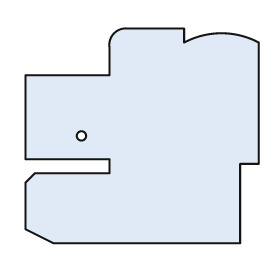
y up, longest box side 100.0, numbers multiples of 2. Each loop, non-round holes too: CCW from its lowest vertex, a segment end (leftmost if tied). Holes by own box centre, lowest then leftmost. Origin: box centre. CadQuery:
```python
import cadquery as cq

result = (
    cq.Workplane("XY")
    .moveTo(-38.0, -46.0)
    .lineTo(42.0, -46.0)
    .lineTo(42.0, -12.0)
    .lineTo(50.0, -12.0)
    .lineTo(50.0, 40.0)
    .threePointArc((34.0, 44.0), (18.0, 40.0))
    .lineTo(18.0, 46.0)
    .lineTo(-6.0, 46.0)
    .threePointArc((-12.0, 44.0), (-14.0, 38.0))
    .lineTo(-14.0, 26.0)
    .lineTo(-50.0, 26.0)
    .lineTo(-50.0, -10.0)
    .lineTo(-14.0, -10.0)
    .lineTo(-14.0, -16.0)
    .lineTo(-46.0, -16.0)
    .lineTo(-50.0, -20.0)
    .lineTo(-50.0, -40.0)
    .close()
    .moveTo(-26.0, 0.0)
    .circle(2.0)
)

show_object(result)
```